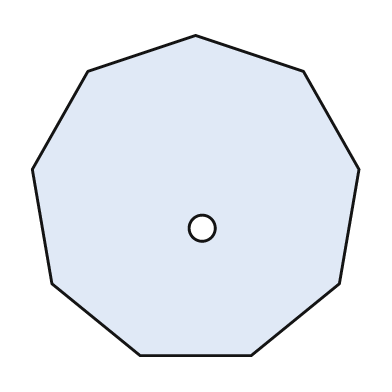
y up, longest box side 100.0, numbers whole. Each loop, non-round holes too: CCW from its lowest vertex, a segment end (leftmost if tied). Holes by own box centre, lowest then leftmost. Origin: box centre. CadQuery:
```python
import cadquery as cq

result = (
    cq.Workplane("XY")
    .moveTo(-17.0, -49.0)
    .lineTo(17.0, -49.0)
    .lineTo(44.0, -27.0)
    .lineTo(50.0, 8.0)
    .lineTo(33.0, 38.0)
    .lineTo(0.0, 49.0)
    .lineTo(-33.0, 38.0)
    .lineTo(-50.0, 8.0)
    .lineTo(-44.0, -27.0)
    .close()
    .moveTo(2.0, -10.0)
    .circle(4.0)
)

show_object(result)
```